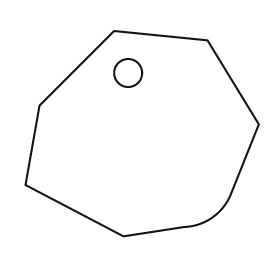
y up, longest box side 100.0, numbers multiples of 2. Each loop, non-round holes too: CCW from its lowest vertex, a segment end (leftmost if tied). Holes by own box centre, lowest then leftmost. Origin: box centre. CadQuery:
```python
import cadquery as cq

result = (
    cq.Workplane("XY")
    .moveTo(-8.0, -44.0)
    .lineTo(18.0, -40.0)
    .threePointArc((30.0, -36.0), (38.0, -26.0))
    .lineTo(50.0, 4.0)
    .lineTo(28.0, 40.0)
    .lineTo(-12.0, 44.0)
    .lineTo(-44.0, 12.0)
    .lineTo(-50.0, -22.0)
    .close()
    .moveTo(-6.0, 26.0)
    .circle(6.0)
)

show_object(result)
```